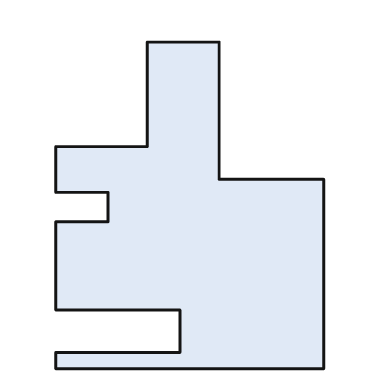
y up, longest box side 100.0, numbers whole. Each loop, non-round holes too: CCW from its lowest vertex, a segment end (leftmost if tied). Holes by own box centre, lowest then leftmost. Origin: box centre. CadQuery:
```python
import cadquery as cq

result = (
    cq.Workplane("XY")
    .moveTo(-41.0, -50.0)
    .lineTo(41.0, -50.0)
    .lineTo(41.0, 8.0)
    .lineTo(9.0, 8.0)
    .lineTo(9.0, 50.0)
    .lineTo(-13.0, 50.0)
    .lineTo(-13.0, 18.0)
    .lineTo(-41.0, 18.0)
    .lineTo(-41.0, 4.0)
    .lineTo(-25.0, 4.0)
    .lineTo(-25.0, -5.0)
    .lineTo(-41.0, -5.0)
    .lineTo(-41.0, -32.0)
    .lineTo(-3.0, -32.0)
    .lineTo(-3.0, -45.0)
    .lineTo(-41.0, -45.0)
    .close()
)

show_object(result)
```